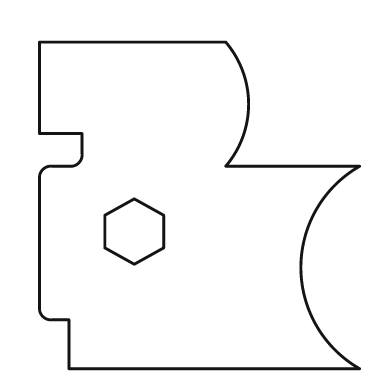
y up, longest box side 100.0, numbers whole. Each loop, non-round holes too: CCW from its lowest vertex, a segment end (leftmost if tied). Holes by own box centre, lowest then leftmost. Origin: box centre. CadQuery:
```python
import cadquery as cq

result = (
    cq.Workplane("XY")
    .moveTo(-40.0, -50.0)
    .lineTo(49.0, -50.0)
    .threePointArc((31.0, -19.0), (49.0, 12.0))
    .lineTo(8.0, 12.0)
    .threePointArc((15.0, 31.0), (8.0, 50.0))
    .lineTo(-49.0, 50.0)
    .lineTo(-49.0, 22.0)
    .lineTo(-36.0, 22.0)
    .lineTo(-36.0, 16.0)
    .threePointArc((-37.0, 13.0), (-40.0, 12.0))
    .lineTo(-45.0, 12.0)
    .threePointArc((-48.0, 11.0), (-49.0, 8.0))
    .lineTo(-49.0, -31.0)
    .threePointArc((-48.0, -34.0), (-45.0, -35.0))
    .lineTo(-40.0, -35.0)
    .close()
    .moveTo(-20.0, -18.0)
    .lineTo(-11.0, -13.0)
    .lineTo(-11.0, -3.0)
    .lineTo(-20.0, 2.0)
    .lineTo(-29.0, -3.0)
    .lineTo(-29.0, -13.0)
    .close()
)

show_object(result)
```